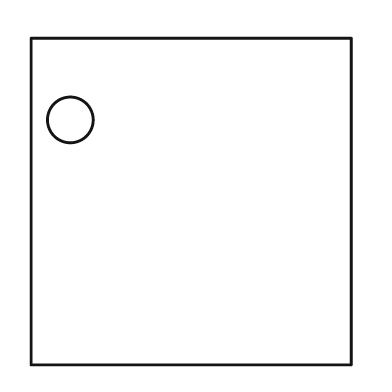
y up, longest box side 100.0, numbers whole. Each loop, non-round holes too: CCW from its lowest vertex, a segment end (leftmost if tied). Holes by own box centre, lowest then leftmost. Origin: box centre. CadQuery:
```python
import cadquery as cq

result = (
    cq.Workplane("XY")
    .moveTo(-49.0, -50.0)
    .lineTo(49.0, -50.0)
    .lineTo(49.0, 50.0)
    .lineTo(-49.0, 50.0)
    .close()
    .moveTo(-37.0, 25.0)
    .circle(7.0)
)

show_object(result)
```